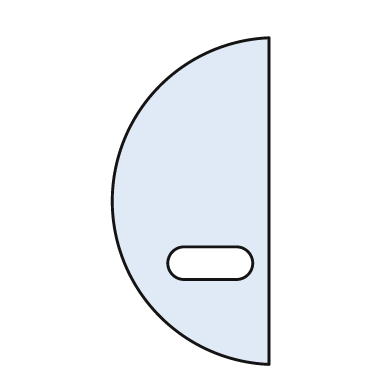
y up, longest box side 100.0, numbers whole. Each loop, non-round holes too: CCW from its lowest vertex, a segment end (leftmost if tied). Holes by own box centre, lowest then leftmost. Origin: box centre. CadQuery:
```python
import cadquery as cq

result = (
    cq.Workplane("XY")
    .moveTo(24.0, -50.0)
    .lineTo(24.0, 50.0)
    .threePointArc((-24.0, 0.0), (24.0, -50.0))
    .close()
    .moveTo(-2.0, -24.0)
    .lineTo(14.0, -24.0)
    .threePointArc((19.0, -19.0), (14.0, -14.0))
    .lineTo(-2.0, -14.0)
    .threePointArc((-7.0, -19.0), (-2.0, -24.0))
    .close()
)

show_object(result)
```